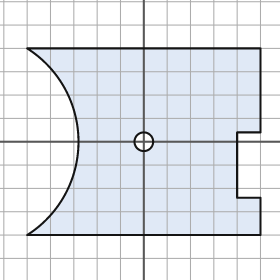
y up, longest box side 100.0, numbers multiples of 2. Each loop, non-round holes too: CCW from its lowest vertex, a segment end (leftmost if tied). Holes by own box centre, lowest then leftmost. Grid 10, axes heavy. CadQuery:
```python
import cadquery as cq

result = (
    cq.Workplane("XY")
    .moveTo(-50.0, -40.0)
    .lineTo(50.0, -40.0)
    .lineTo(50.0, -24.0)
    .lineTo(40.0, -24.0)
    .lineTo(40.0, 4.0)
    .lineTo(50.0, 4.0)
    .lineTo(50.0, 40.0)
    .lineTo(-50.0, 40.0)
    .threePointArc((-28.0, 0.0), (-50.0, -40.0))
    .close()
    .moveTo(0.0, 0.0)
    .circle(4.0)
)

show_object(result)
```